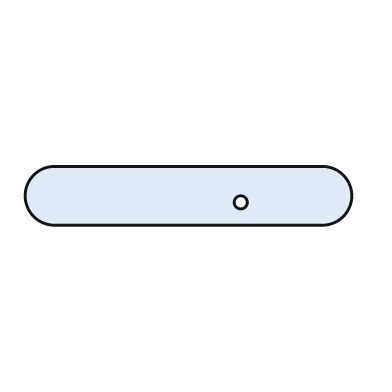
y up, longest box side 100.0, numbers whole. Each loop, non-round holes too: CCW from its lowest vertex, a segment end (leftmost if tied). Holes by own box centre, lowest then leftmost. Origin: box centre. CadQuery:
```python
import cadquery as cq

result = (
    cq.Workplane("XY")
    .moveTo(-41.0, -9.0)
    .lineTo(41.0, -9.0)
    .threePointArc((50.0, 0.0), (41.0, 9.0))
    .lineTo(-41.0, 9.0)
    .threePointArc((-50.0, 0.0), (-41.0, -9.0))
    .close()
    .moveTo(16.0, -2.0)
    .circle(2.0)
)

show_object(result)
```